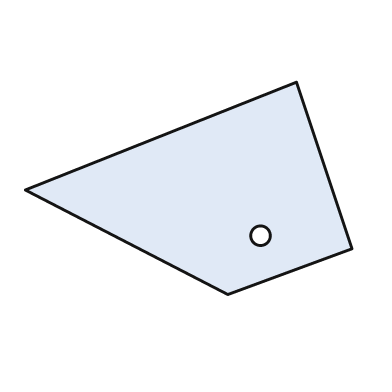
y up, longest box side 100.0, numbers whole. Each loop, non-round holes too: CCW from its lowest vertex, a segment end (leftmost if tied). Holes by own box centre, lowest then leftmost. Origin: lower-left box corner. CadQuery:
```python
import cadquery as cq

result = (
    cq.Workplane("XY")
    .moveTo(62.0, 0.0)
    .lineTo(100.0, 14.0)
    .lineTo(83.0, 65.0)
    .lineTo(0.0, 32.0)
    .close()
    .moveTo(72.0, 18.0)
    .circle(3.0)
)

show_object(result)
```